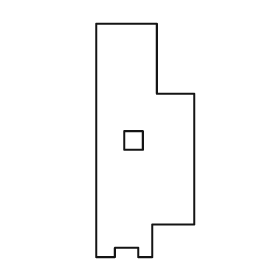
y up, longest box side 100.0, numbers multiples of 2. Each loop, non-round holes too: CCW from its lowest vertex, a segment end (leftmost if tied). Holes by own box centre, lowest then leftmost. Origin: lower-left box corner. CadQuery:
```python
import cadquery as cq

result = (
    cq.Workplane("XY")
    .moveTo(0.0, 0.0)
    .lineTo(8.0, 0.0)
    .lineTo(8.0, 4.0)
    .lineTo(18.0, 4.0)
    .lineTo(18.0, 0.0)
    .lineTo(24.0, 0.0)
    .lineTo(24.0, 14.0)
    .lineTo(42.0, 14.0)
    .lineTo(42.0, 70.0)
    .lineTo(26.0, 70.0)
    .lineTo(26.0, 100.0)
    .lineTo(0.0, 100.0)
    .close()
    .moveTo(12.0, 46.0)
    .lineTo(20.0, 46.0)
    .lineTo(20.0, 54.0)
    .lineTo(12.0, 54.0)
    .close()
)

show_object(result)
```